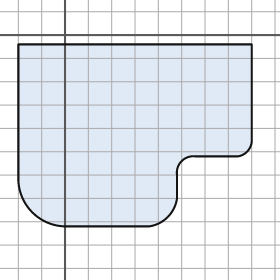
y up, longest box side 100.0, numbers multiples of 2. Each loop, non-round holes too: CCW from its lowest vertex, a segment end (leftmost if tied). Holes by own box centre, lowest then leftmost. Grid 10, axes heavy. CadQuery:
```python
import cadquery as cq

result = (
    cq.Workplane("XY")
    .moveTo(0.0, -82.0)
    .lineTo(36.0, -82.0)
    .threePointArc((44.0, -78.0), (48.0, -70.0))
    .lineTo(48.0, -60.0)
    .threePointArc((50.0, -54.0), (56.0, -52.0))
    .lineTo(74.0, -52.0)
    .threePointArc((78.0, -50.0), (80.0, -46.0))
    .lineTo(80.0, -4.0)
    .lineTo(-20.0, -4.0)
    .lineTo(-20.0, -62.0)
    .threePointArc((-14.0, -76.0), (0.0, -82.0))
    .close()
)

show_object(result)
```